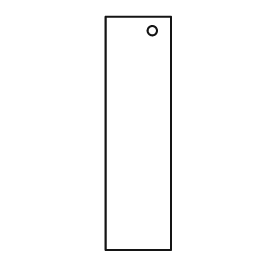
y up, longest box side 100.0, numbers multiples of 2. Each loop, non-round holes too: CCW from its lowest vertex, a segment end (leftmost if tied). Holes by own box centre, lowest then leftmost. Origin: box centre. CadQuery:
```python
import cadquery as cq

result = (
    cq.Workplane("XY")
    .moveTo(-14.0, -50.0)
    .lineTo(14.0, -50.0)
    .lineTo(14.0, 50.0)
    .lineTo(-14.0, 50.0)
    .close()
    .moveTo(6.0, 44.0)
    .circle(2.0)
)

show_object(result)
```